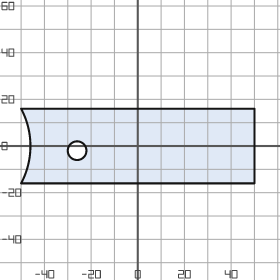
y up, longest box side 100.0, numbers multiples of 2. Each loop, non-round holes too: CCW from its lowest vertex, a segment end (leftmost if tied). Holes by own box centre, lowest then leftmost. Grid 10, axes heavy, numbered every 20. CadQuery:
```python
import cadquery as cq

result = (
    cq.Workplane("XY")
    .moveTo(-50.0, -16.0)
    .lineTo(50.0, -16.0)
    .lineTo(50.0, 16.0)
    .lineTo(-50.0, 16.0)
    .threePointArc((-46.0, 0.0), (-50.0, -16.0))
    .close()
    .moveTo(-26.0, -2.0)
    .circle(4.0)
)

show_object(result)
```